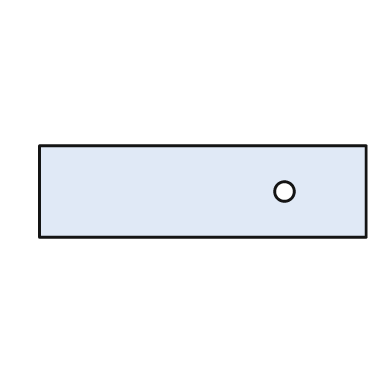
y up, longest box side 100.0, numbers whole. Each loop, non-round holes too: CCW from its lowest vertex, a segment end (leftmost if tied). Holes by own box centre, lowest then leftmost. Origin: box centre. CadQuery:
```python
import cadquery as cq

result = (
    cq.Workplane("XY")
    .moveTo(-50.0, -14.0)
    .lineTo(50.0, -14.0)
    .lineTo(50.0, 14.0)
    .lineTo(-50.0, 14.0)
    .close()
    .moveTo(25.0, 0.0)
    .circle(3.0)
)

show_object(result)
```